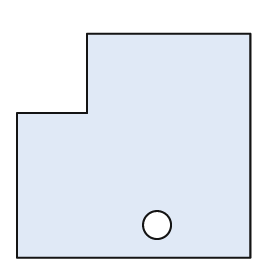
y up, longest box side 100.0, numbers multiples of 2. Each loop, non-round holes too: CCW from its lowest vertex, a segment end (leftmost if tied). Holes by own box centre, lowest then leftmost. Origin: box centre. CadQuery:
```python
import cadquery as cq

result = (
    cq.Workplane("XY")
    .moveTo(-50.0, -48.0)
    .lineTo(50.0, -48.0)
    .lineTo(50.0, 48.0)
    .lineTo(-20.0, 48.0)
    .lineTo(-20.0, 14.0)
    .lineTo(-50.0, 14.0)
    .close()
    .moveTo(10.0, -34.0)
    .circle(6.0)
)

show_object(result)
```